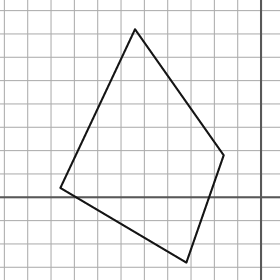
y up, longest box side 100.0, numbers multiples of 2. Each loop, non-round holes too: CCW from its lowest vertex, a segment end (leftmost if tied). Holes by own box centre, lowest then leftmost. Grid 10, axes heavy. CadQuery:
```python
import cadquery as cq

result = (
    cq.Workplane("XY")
    .moveTo(-32.0, -28.0)
    .lineTo(-16.0, 18.0)
    .lineTo(-54.0, 72.0)
    .lineTo(-86.0, 4.0)
    .close()
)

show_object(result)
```